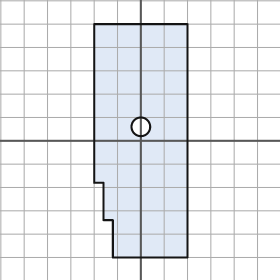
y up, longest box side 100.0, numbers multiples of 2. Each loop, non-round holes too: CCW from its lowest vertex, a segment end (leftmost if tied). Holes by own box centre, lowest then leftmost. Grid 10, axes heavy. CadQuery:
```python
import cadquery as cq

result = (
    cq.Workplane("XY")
    .moveTo(-12.0, -50.0)
    .lineTo(20.0, -50.0)
    .lineTo(20.0, 50.0)
    .lineTo(-20.0, 50.0)
    .lineTo(-20.0, -18.0)
    .lineTo(-16.0, -18.0)
    .lineTo(-16.0, -34.0)
    .lineTo(-12.0, -34.0)
    .close()
    .moveTo(0.0, 6.0)
    .circle(4.0)
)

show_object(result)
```